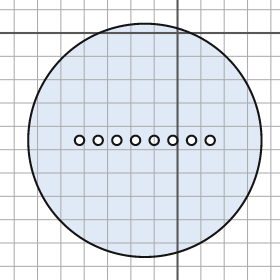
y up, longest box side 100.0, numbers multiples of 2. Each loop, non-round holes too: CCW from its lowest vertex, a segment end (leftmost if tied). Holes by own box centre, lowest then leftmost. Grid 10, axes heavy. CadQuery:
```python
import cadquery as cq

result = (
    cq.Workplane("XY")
    .moveTo(-14.0, -46.0)
    .circle(50.0)
    .moveTo(-42.0, -46.0)
    .circle(2.0)
    .moveTo(-34.0, -46.0)
    .circle(2.0)
    .moveTo(-26.0, -46.0)
    .circle(2.0)
    .moveTo(-18.0, -46.0)
    .circle(2.0)
    .moveTo(-10.0, -46.0)
    .circle(2.0)
    .moveTo(-2.0, -46.0)
    .circle(2.0)
    .moveTo(6.0, -46.0)
    .circle(2.0)
    .moveTo(14.0, -46.0)
    .circle(2.0)
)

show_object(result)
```